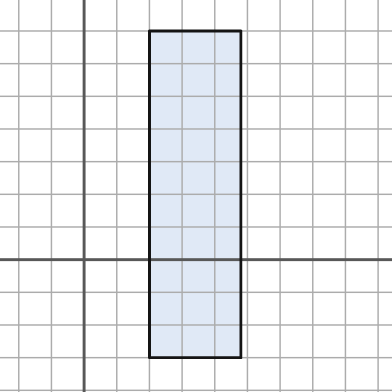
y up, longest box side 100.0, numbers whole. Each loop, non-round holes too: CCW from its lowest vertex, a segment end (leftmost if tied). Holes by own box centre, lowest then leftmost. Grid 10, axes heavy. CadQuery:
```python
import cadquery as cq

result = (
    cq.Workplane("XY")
    .moveTo(20.0, -30.0)
    .lineTo(48.0, -30.0)
    .lineTo(48.0, 70.0)
    .lineTo(20.0, 70.0)
    .close()
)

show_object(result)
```